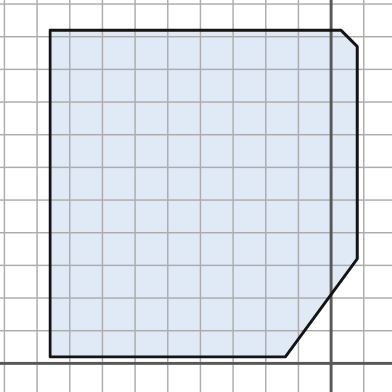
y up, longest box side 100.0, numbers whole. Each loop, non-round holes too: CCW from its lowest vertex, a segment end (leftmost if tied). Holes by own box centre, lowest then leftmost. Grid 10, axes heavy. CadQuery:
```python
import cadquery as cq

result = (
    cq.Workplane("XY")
    .moveTo(-86.0, 2.0)
    .lineTo(-14.0, 2.0)
    .lineTo(8.0, 32.0)
    .lineTo(8.0, 97.0)
    .lineTo(3.0, 102.0)
    .lineTo(-86.0, 102.0)
    .close()
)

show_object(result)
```